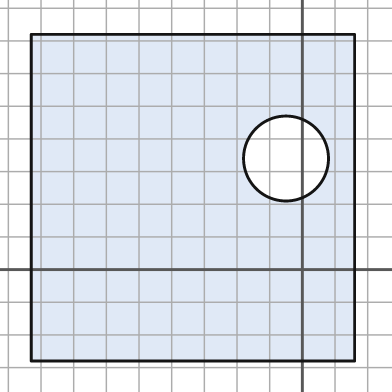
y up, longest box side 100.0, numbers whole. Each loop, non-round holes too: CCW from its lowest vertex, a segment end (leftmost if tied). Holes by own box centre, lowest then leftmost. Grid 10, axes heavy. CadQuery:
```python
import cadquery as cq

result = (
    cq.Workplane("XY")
    .moveTo(-83.0, -28.0)
    .lineTo(16.0, -28.0)
    .lineTo(16.0, 72.0)
    .lineTo(-83.0, 72.0)
    .close()
    .moveTo(-5.0, 34.0)
    .circle(13.0)
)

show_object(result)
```